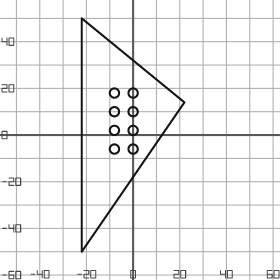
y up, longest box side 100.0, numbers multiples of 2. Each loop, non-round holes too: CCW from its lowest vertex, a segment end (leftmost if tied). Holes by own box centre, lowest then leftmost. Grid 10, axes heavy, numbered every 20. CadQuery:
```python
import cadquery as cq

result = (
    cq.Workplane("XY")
    .moveTo(-22.0, -50.0)
    .lineTo(22.0, 14.0)
    .lineTo(-22.0, 50.0)
    .close()
    .moveTo(-8.0, -6.0)
    .circle(2.0)
    .moveTo(0.0, -6.0)
    .circle(2.0)
    .moveTo(-8.0, 2.0)
    .circle(2.0)
    .moveTo(0.0, 2.0)
    .circle(2.0)
    .moveTo(-8.0, 10.0)
    .circle(2.0)
    .moveTo(0.0, 10.0)
    .circle(2.0)
    .moveTo(-8.0, 18.0)
    .circle(2.0)
    .moveTo(0.0, 18.0)
    .circle(2.0)
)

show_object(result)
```